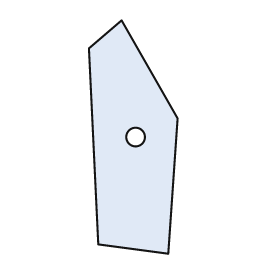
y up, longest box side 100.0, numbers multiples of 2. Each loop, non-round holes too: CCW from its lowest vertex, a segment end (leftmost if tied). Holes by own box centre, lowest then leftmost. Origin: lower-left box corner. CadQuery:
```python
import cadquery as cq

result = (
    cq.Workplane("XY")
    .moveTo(34.0, 0.0)
    .lineTo(38.0, 58.0)
    .lineTo(14.0, 100.0)
    .lineTo(0.0, 88.0)
    .lineTo(4.0, 4.0)
    .close()
    .moveTo(20.0, 50.0)
    .circle(4.0)
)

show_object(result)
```